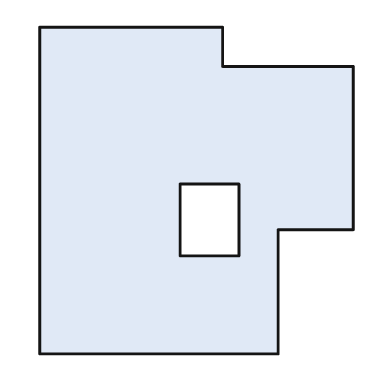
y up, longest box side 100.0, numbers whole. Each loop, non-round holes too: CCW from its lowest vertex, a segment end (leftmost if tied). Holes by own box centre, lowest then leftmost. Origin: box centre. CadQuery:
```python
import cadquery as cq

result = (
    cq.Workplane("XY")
    .moveTo(-48.0, -50.0)
    .lineTo(25.0, -50.0)
    .lineTo(25.0, -12.0)
    .lineTo(48.0, -12.0)
    .lineTo(48.0, 38.0)
    .lineTo(8.0, 38.0)
    .lineTo(8.0, 50.0)
    .lineTo(-48.0, 50.0)
    .close()
    .moveTo(-5.0, -20.0)
    .lineTo(13.0, -20.0)
    .lineTo(13.0, 2.0)
    .lineTo(-5.0, 2.0)
    .close()
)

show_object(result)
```